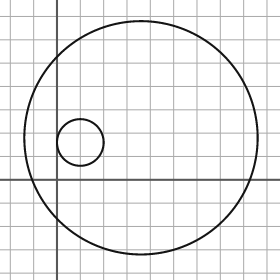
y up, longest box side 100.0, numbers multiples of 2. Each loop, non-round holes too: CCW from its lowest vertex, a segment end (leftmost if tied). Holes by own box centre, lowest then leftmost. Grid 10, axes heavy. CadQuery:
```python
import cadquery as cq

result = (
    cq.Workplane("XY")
    .moveTo(36.0, 18.0)
    .circle(50.0)
    .moveTo(10.0, 16.0)
    .circle(10.0)
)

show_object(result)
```